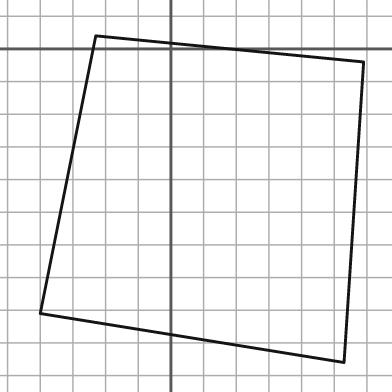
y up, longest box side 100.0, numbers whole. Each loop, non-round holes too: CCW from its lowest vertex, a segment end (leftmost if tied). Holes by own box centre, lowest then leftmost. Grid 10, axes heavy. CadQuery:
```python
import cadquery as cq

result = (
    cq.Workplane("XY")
    .moveTo(53.0, -96.0)
    .lineTo(59.0, -4.0)
    .lineTo(-23.0, 4.0)
    .lineTo(-40.0, -81.0)
    .close()
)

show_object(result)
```